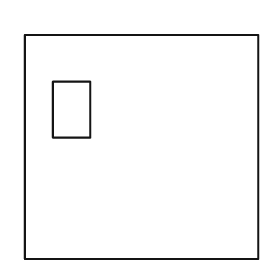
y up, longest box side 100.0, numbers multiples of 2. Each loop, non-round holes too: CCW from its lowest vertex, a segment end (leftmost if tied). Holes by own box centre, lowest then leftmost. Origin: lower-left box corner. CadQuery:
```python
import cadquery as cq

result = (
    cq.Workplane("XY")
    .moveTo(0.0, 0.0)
    .lineTo(100.0, 0.0)
    .lineTo(100.0, 96.0)
    .lineTo(0.0, 96.0)
    .close()
    .moveTo(12.0, 52.0)
    .lineTo(28.0, 52.0)
    .lineTo(28.0, 76.0)
    .lineTo(12.0, 76.0)
    .close()
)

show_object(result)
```